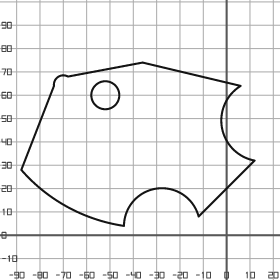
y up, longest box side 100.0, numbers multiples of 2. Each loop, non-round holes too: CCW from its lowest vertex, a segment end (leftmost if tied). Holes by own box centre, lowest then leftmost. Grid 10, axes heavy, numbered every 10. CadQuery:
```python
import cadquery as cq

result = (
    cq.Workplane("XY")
    .moveTo(-44.0, 4.0)
    .threePointArc((-30.0, 20.0), (-12.0, 8.0))
    .lineTo(12.0, 32.0)
    .threePointArc((-2.0, 46.0), (6.0, 64.0))
    .lineTo(-36.0, 74.0)
    .lineTo(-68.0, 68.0)
    .threePointArc((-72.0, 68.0), (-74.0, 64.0))
    .lineTo(-88.0, 28.0)
    .threePointArc((-68.0, 12.0), (-44.0, 4.0))
    .close()
    .moveTo(-52.0, 60.0)
    .circle(6.0)
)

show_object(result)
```